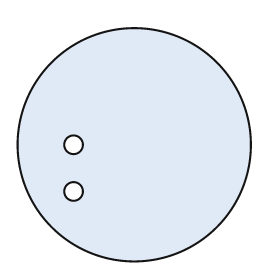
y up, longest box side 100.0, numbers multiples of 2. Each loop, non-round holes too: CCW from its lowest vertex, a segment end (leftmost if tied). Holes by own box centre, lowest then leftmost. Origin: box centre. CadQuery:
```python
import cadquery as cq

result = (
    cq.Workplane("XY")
    .moveTo(0.0, 0.0)
    .circle(50.0)
    .moveTo(-26.0, -20.0)
    .circle(4.0)
    .moveTo(-26.0, 0.0)
    .circle(4.0)
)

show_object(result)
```